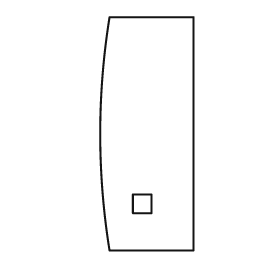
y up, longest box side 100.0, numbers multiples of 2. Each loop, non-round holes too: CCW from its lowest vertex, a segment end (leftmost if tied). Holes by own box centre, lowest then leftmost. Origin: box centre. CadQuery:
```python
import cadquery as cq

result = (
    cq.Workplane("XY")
    .moveTo(-16.0, -50.0)
    .lineTo(20.0, -50.0)
    .lineTo(20.0, 50.0)
    .lineTo(-16.0, 50.0)
    .threePointArc((-20.0, 0.0), (-16.0, -50.0))
    .close()
    .moveTo(-6.0, -34.0)
    .lineTo(2.0, -34.0)
    .lineTo(2.0, -26.0)
    .lineTo(-6.0, -26.0)
    .close()
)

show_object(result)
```